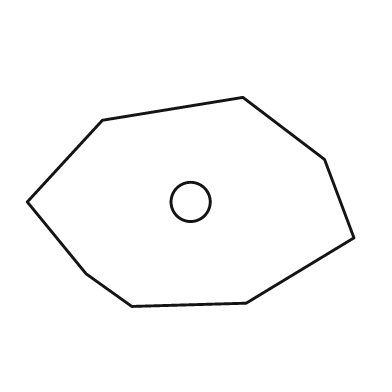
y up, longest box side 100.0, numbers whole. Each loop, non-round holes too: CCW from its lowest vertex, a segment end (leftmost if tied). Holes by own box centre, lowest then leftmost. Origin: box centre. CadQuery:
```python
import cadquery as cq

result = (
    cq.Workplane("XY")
    .moveTo(-18.0, -32.0)
    .lineTo(17.0, -31.0)
    .lineTo(50.0, -11.0)
    .lineTo(41.0, 13.0)
    .lineTo(16.0, 32.0)
    .lineTo(-27.0, 25.0)
    .lineTo(-50.0, 0.0)
    .lineTo(-32.0, -22.0)
    .close()
    .moveTo(0.0, 0.0)
    .circle(6.0)
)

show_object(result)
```